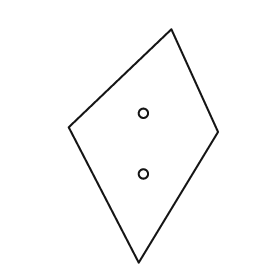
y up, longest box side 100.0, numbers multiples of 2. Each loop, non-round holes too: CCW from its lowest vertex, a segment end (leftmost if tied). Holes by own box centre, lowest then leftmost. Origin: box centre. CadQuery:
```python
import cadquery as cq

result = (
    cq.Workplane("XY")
    .moveTo(-2.0, -50.0)
    .lineTo(32.0, 6.0)
    .lineTo(12.0, 50.0)
    .lineTo(-32.0, 8.0)
    .close()
    .moveTo(0.0, -12.0)
    .circle(2.0)
    .moveTo(0.0, 14.0)
    .circle(2.0)
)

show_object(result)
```